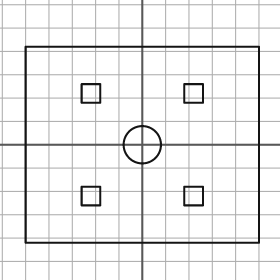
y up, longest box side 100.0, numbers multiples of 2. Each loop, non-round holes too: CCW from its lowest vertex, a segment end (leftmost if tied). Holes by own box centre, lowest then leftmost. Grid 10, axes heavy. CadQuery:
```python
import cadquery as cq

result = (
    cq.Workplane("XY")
    .moveTo(-50.0, -42.0)
    .lineTo(50.0, -42.0)
    .lineTo(50.0, 42.0)
    .lineTo(-50.0, 42.0)
    .close()
    .moveTo(-26.0, -26.0)
    .lineTo(-18.0, -26.0)
    .lineTo(-18.0, -18.0)
    .lineTo(-26.0, -18.0)
    .close()
    .moveTo(18.0, -26.0)
    .lineTo(26.0, -26.0)
    .lineTo(26.0, -18.0)
    .lineTo(18.0, -18.0)
    .close()
    .moveTo(0.0, 0.0)
    .circle(8.0)
    .moveTo(-26.0, 18.0)
    .lineTo(-18.0, 18.0)
    .lineTo(-18.0, 26.0)
    .lineTo(-26.0, 26.0)
    .close()
    .moveTo(18.0, 18.0)
    .lineTo(26.0, 18.0)
    .lineTo(26.0, 26.0)
    .lineTo(18.0, 26.0)
    .close()
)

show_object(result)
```